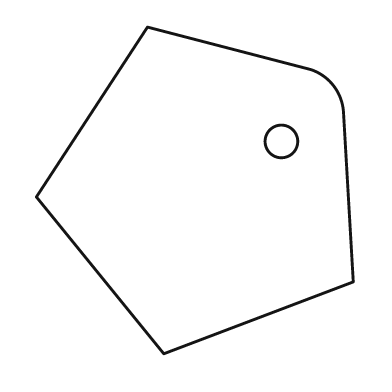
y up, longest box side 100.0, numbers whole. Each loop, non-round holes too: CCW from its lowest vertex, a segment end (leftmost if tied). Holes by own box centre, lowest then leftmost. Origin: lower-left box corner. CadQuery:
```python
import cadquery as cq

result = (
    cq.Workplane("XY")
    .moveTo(39.0, 0.0)
    .lineTo(97.0, 22.0)
    .lineTo(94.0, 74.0)
    .threePointArc((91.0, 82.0), (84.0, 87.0))
    .lineTo(34.0, 100.0)
    .lineTo(0.0, 48.0)
    .close()
    .moveTo(75.0, 65.0)
    .circle(5.0)
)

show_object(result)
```